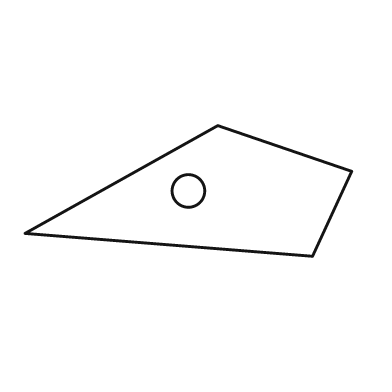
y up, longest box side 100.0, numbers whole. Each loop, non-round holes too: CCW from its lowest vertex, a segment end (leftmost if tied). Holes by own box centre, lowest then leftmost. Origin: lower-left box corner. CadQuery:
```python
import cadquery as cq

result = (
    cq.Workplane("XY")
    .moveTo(88.0, 0.0)
    .lineTo(100.0, 26.0)
    .lineTo(59.0, 40.0)
    .lineTo(0.0, 7.0)
    .close()
    .moveTo(50.0, 20.0)
    .circle(5.0)
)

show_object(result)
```